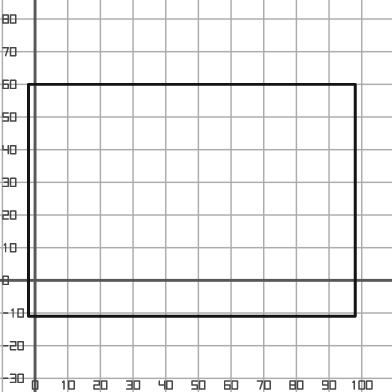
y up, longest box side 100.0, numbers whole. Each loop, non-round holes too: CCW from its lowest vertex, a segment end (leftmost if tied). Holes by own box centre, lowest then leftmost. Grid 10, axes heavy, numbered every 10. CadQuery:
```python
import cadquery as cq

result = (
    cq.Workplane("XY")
    .moveTo(-2.0, -11.0)
    .lineTo(98.0, -11.0)
    .lineTo(98.0, 60.0)
    .lineTo(-2.0, 60.0)
    .close()
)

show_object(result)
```